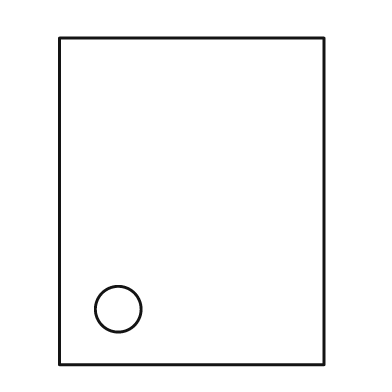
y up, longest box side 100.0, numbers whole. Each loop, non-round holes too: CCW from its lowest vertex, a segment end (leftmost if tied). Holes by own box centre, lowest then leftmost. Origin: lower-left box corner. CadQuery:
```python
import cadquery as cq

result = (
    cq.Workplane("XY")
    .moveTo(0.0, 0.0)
    .lineTo(81.0, 0.0)
    .lineTo(81.0, 100.0)
    .lineTo(0.0, 100.0)
    .close()
    .moveTo(18.0, 17.0)
    .circle(7.0)
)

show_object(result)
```